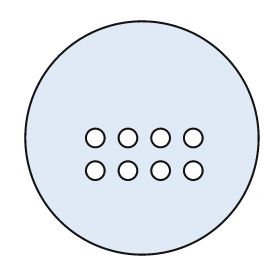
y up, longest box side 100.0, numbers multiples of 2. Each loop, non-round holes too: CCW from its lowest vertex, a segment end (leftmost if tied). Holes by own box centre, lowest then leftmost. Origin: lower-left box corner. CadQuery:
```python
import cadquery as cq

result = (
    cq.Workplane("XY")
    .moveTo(50.0, 50.0)
    .circle(50.0)
    .moveTo(30.0, 36.0)
    .circle(4.0)
    .moveTo(44.0, 36.0)
    .circle(4.0)
    .moveTo(58.0, 36.0)
    .circle(4.0)
    .moveTo(72.0, 36.0)
    .circle(4.0)
    .moveTo(30.0, 50.0)
    .circle(4.0)
    .moveTo(44.0, 50.0)
    .circle(4.0)
    .moveTo(58.0, 50.0)
    .circle(4.0)
    .moveTo(72.0, 50.0)
    .circle(4.0)
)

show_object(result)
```